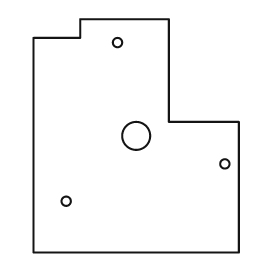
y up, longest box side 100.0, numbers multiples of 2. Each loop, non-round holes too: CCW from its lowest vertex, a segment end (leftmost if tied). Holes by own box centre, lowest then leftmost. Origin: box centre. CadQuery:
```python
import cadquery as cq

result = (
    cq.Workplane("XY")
    .moveTo(-44.0, -50.0)
    .lineTo(44.0, -50.0)
    .lineTo(44.0, 6.0)
    .lineTo(14.0, 6.0)
    .lineTo(14.0, 50.0)
    .lineTo(-24.0, 50.0)
    .lineTo(-24.0, 42.0)
    .lineTo(-44.0, 42.0)
    .close()
    .moveTo(-30.0, -28.0)
    .circle(2.0)
    .moveTo(38.0, -12.0)
    .circle(2.0)
    .moveTo(0.0, 0.0)
    .circle(6.0)
    .moveTo(-8.0, 40.0)
    .circle(2.0)
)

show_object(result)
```